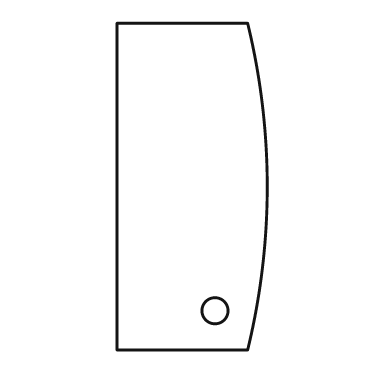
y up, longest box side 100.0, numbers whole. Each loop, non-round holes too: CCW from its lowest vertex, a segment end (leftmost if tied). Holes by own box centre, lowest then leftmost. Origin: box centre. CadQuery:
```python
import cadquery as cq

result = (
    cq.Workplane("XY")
    .moveTo(-23.0, -50.0)
    .lineTo(17.0, -50.0)
    .threePointArc((23.0, 0.0), (17.0, 50.0))
    .lineTo(-23.0, 50.0)
    .close()
    .moveTo(7.0, -38.0)
    .circle(4.0)
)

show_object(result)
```